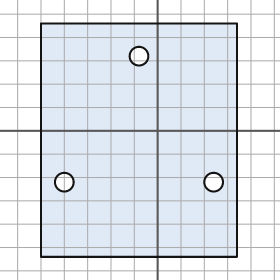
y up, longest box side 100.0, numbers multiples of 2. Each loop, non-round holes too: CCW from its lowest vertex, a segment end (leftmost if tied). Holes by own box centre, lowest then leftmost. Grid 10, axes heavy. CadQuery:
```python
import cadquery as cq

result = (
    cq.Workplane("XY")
    .moveTo(-50.0, -54.0)
    .lineTo(34.0, -54.0)
    .lineTo(34.0, 46.0)
    .lineTo(-50.0, 46.0)
    .close()
    .moveTo(-40.0, -22.0)
    .circle(4.0)
    .moveTo(24.0, -22.0)
    .circle(4.0)
    .moveTo(-8.0, 32.0)
    .circle(4.0)
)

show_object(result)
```